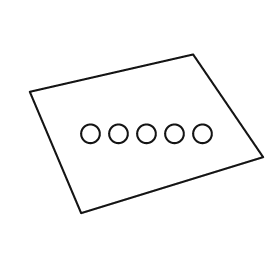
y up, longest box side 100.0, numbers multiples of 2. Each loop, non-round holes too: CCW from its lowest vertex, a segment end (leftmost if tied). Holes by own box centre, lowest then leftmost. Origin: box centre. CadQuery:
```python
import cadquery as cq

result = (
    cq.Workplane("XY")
    .moveTo(-28.0, -34.0)
    .lineTo(50.0, -10.0)
    .lineTo(20.0, 34.0)
    .lineTo(-50.0, 18.0)
    .close()
    .moveTo(-24.0, 0.0)
    .circle(4.0)
    .moveTo(-12.0, 0.0)
    .circle(4.0)
    .moveTo(0.0, 0.0)
    .circle(4.0)
    .moveTo(12.0, 0.0)
    .circle(4.0)
    .moveTo(24.0, 0.0)
    .circle(4.0)
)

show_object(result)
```